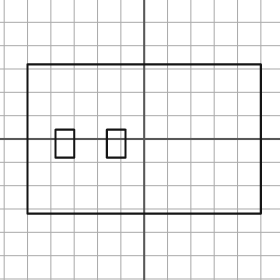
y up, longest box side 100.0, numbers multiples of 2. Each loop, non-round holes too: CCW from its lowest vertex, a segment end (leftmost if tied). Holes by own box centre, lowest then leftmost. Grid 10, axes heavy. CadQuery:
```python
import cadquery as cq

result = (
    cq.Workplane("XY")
    .moveTo(-50.0, -32.0)
    .lineTo(50.0, -32.0)
    .lineTo(50.0, 32.0)
    .lineTo(-50.0, 32.0)
    .close()
    .moveTo(-38.0, -8.0)
    .lineTo(-30.0, -8.0)
    .lineTo(-30.0, 4.0)
    .lineTo(-38.0, 4.0)
    .close()
    .moveTo(-16.0, -8.0)
    .lineTo(-8.0, -8.0)
    .lineTo(-8.0, 4.0)
    .lineTo(-16.0, 4.0)
    .close()
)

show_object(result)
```